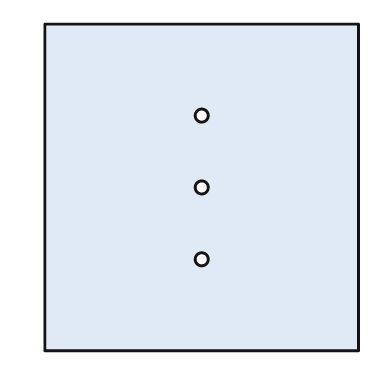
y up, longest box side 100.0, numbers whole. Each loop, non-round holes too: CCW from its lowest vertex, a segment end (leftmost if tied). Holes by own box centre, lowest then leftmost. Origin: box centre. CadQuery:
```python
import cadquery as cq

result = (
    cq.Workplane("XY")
    .moveTo(-48.0, -50.0)
    .lineTo(48.0, -50.0)
    .lineTo(48.0, 50.0)
    .lineTo(-48.0, 50.0)
    .close()
    .moveTo(0.0, -22.0)
    .circle(2.0)
    .moveTo(0.0, 0.0)
    .circle(2.0)
    .moveTo(0.0, 22.0)
    .circle(2.0)
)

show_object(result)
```